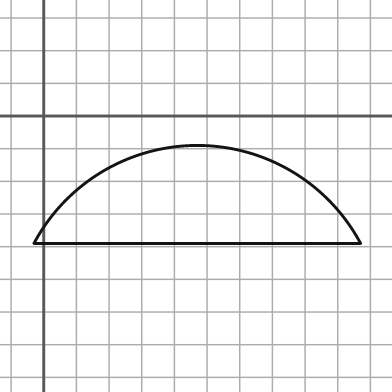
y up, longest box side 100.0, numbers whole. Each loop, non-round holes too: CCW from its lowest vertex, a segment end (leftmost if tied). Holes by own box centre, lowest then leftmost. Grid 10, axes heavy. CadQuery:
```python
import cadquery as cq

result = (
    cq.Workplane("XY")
    .moveTo(-3.0, -39.0)
    .lineTo(97.0, -39.0)
    .threePointArc((47.0, -9.0), (-3.0, -39.0))
    .close()
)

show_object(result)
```